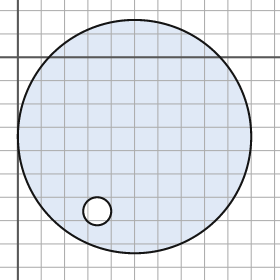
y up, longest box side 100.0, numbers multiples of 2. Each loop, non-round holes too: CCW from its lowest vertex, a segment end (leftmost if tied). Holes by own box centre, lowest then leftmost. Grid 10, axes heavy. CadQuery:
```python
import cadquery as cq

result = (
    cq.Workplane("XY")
    .moveTo(50.0, -34.0)
    .circle(50.0)
    .moveTo(34.0, -66.0)
    .circle(6.0)
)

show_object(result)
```